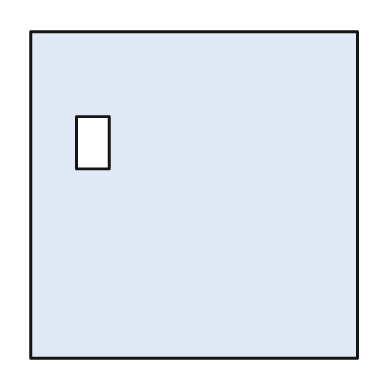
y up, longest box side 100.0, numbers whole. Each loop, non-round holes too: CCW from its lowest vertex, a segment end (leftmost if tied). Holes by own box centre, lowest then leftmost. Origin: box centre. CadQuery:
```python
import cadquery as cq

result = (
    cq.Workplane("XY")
    .moveTo(-50.0, -50.0)
    .lineTo(50.0, -50.0)
    .lineTo(50.0, 50.0)
    .lineTo(-50.0, 50.0)
    .close()
    .moveTo(-36.0, 8.0)
    .lineTo(-26.0, 8.0)
    .lineTo(-26.0, 24.0)
    .lineTo(-36.0, 24.0)
    .close()
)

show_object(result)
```